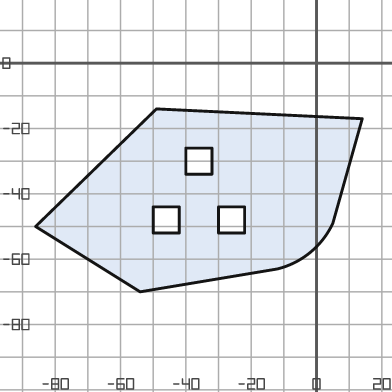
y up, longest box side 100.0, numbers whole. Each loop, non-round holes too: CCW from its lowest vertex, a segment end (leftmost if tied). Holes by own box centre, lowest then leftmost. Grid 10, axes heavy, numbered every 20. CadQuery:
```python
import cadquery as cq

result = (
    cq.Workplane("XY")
    .moveTo(-54.0, -70.0)
    .lineTo(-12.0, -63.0)
    .threePointArc((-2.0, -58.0), (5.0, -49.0))
    .lineTo(14.0, -17.0)
    .lineTo(-49.0, -14.0)
    .lineTo(-86.0, -50.0)
    .close()
    .moveTo(-50.0, -52.0)
    .lineTo(-42.0, -52.0)
    .lineTo(-42.0, -44.0)
    .lineTo(-50.0, -44.0)
    .close()
    .moveTo(-30.0, -52.0)
    .lineTo(-22.0, -52.0)
    .lineTo(-22.0, -44.0)
    .lineTo(-30.0, -44.0)
    .close()
    .moveTo(-40.0, -34.0)
    .lineTo(-32.0, -34.0)
    .lineTo(-32.0, -26.0)
    .lineTo(-40.0, -26.0)
    .close()
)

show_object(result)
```